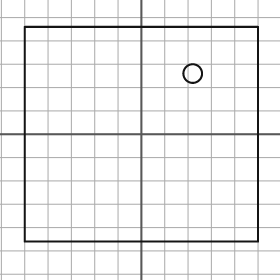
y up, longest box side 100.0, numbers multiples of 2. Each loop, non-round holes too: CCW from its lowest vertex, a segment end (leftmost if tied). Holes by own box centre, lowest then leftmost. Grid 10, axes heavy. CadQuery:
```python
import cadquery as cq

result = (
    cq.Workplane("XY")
    .moveTo(-50.0, -46.0)
    .lineTo(50.0, -46.0)
    .lineTo(50.0, 46.0)
    .lineTo(-50.0, 46.0)
    .close()
    .moveTo(22.0, 26.0)
    .circle(4.0)
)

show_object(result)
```